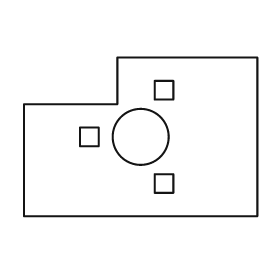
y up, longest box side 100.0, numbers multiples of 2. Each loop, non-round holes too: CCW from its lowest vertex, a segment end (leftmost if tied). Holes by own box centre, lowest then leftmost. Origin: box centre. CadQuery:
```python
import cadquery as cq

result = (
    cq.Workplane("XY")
    .moveTo(-50.0, -34.0)
    .lineTo(50.0, -34.0)
    .lineTo(50.0, 34.0)
    .lineTo(-10.0, 34.0)
    .lineTo(-10.0, 14.0)
    .lineTo(-50.0, 14.0)
    .close()
    .moveTo(6.0, -24.0)
    .lineTo(14.0, -24.0)
    .lineTo(14.0, -16.0)
    .lineTo(6.0, -16.0)
    .close()
    .moveTo(-26.0, -4.0)
    .lineTo(-18.0, -4.0)
    .lineTo(-18.0, 4.0)
    .lineTo(-26.0, 4.0)
    .close()
    .moveTo(0.0, 0.0)
    .circle(12.0)
    .moveTo(6.0, 16.0)
    .lineTo(14.0, 16.0)
    .lineTo(14.0, 24.0)
    .lineTo(6.0, 24.0)
    .close()
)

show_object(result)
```